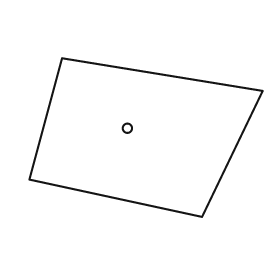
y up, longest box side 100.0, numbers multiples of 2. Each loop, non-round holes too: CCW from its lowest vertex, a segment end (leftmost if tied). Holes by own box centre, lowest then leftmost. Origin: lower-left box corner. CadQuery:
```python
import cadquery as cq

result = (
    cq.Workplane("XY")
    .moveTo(74.0, 0.0)
    .lineTo(100.0, 54.0)
    .lineTo(14.0, 68.0)
    .lineTo(0.0, 16.0)
    .close()
    .moveTo(42.0, 38.0)
    .circle(2.0)
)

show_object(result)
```